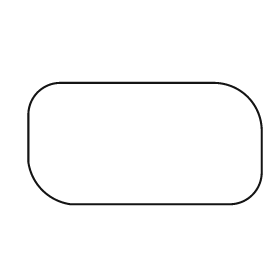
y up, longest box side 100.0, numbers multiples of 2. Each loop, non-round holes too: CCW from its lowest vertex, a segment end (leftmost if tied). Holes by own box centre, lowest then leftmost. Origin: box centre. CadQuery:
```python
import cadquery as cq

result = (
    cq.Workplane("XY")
    .moveTo(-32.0, -26.0)
    .lineTo(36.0, -26.0)
    .threePointArc((46.0, -22.0), (50.0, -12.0))
    .lineTo(50.0, 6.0)
    .threePointArc((44.0, 20.0), (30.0, 26.0))
    .lineTo(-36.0, 26.0)
    .threePointArc((-46.0, 22.0), (-50.0, 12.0))
    .lineTo(-50.0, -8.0)
    .threePointArc((-44.0, -20.0), (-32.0, -26.0))
    .close()
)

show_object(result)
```